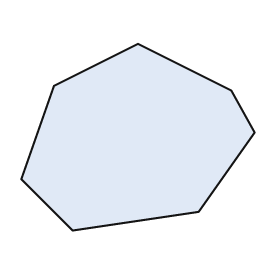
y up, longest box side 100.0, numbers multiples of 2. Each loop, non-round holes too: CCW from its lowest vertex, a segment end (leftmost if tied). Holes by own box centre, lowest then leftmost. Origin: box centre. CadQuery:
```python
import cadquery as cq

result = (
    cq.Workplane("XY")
    .moveTo(-28.0, -40.0)
    .lineTo(26.0, -32.0)
    .lineTo(50.0, 2.0)
    .lineTo(40.0, 20.0)
    .lineTo(0.0, 40.0)
    .lineTo(-36.0, 22.0)
    .lineTo(-50.0, -18.0)
    .close()
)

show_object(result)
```